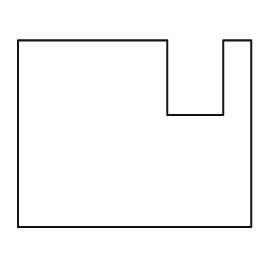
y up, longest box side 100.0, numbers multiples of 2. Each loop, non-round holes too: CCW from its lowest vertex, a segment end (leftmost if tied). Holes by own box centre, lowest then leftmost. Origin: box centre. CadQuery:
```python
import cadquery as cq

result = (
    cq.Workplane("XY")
    .moveTo(-50.0, -40.0)
    .lineTo(50.0, -40.0)
    .lineTo(50.0, 40.0)
    .lineTo(38.0, 40.0)
    .lineTo(38.0, 8.0)
    .lineTo(14.0, 8.0)
    .lineTo(14.0, 40.0)
    .lineTo(-50.0, 40.0)
    .close()
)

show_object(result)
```